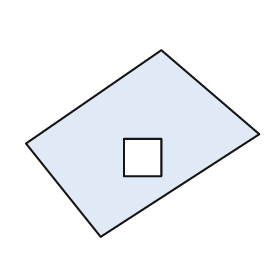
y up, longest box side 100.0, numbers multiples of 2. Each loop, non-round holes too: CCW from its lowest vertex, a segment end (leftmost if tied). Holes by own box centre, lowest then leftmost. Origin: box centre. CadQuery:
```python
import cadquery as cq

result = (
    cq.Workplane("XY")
    .moveTo(-18.0, -40.0)
    .lineTo(50.0, 4.0)
    .lineTo(8.0, 40.0)
    .lineTo(-50.0, 0.0)
    .close()
    .moveTo(-8.0, -14.0)
    .lineTo(8.0, -14.0)
    .lineTo(8.0, 2.0)
    .lineTo(-8.0, 2.0)
    .close()
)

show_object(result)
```